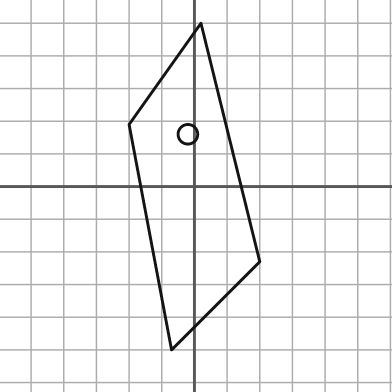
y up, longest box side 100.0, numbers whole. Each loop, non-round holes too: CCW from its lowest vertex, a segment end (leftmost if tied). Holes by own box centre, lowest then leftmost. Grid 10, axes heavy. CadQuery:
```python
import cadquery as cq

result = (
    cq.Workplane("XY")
    .moveTo(-7.0, -50.0)
    .lineTo(20.0, -23.0)
    .lineTo(2.0, 50.0)
    .lineTo(-20.0, 19.0)
    .close()
    .moveTo(-2.0, 16.0)
    .circle(3.0)
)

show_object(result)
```